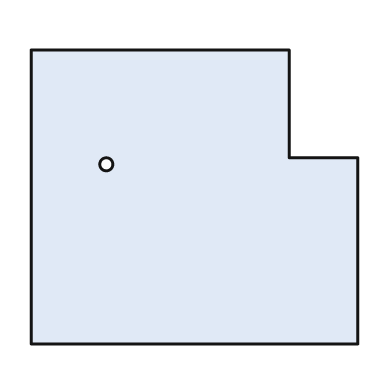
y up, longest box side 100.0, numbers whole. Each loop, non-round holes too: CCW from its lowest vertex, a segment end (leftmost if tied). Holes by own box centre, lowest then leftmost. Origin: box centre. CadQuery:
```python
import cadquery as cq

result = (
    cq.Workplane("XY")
    .moveTo(-50.0, -45.0)
    .lineTo(50.0, -45.0)
    .lineTo(50.0, 12.0)
    .lineTo(29.0, 12.0)
    .lineTo(29.0, 45.0)
    .lineTo(-50.0, 45.0)
    .close()
    .moveTo(-27.0, 10.0)
    .circle(2.0)
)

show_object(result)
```